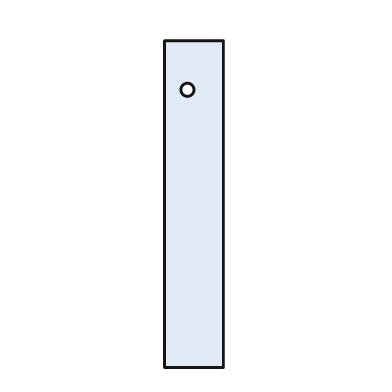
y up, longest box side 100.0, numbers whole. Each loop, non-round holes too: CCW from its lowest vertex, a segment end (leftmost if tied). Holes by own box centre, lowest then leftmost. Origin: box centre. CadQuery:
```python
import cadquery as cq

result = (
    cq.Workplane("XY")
    .moveTo(-9.0, -50.0)
    .lineTo(9.0, -50.0)
    .lineTo(9.0, 50.0)
    .lineTo(-9.0, 50.0)
    .close()
    .moveTo(-2.0, 35.0)
    .circle(2.0)
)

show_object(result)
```